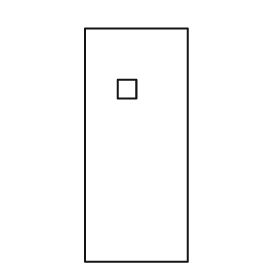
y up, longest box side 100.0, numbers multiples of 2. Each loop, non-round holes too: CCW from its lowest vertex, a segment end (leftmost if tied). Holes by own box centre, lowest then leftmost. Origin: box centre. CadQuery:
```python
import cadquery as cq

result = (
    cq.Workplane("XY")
    .moveTo(-22.0, -50.0)
    .lineTo(22.0, -50.0)
    .lineTo(22.0, 50.0)
    .lineTo(-22.0, 50.0)
    .close()
    .moveTo(-8.0, 20.0)
    .lineTo(0.0, 20.0)
    .lineTo(0.0, 28.0)
    .lineTo(-8.0, 28.0)
    .close()
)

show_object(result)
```